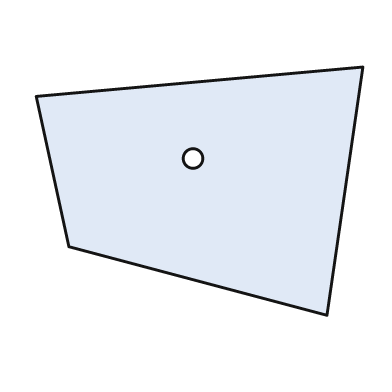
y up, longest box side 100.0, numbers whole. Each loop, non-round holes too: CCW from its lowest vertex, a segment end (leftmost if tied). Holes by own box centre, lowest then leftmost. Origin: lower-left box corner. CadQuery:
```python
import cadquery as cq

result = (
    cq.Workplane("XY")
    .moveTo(89.0, 0.0)
    .lineTo(100.0, 76.0)
    .lineTo(0.0, 67.0)
    .lineTo(10.0, 21.0)
    .close()
    .moveTo(48.0, 48.0)
    .circle(3.0)
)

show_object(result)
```